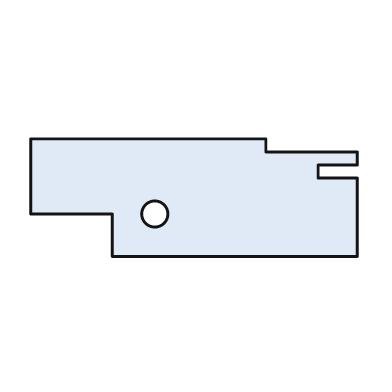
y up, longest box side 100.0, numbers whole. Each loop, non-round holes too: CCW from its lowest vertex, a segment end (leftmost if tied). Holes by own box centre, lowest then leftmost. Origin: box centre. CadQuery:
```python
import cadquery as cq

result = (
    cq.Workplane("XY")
    .moveTo(-25.0, -18.0)
    .lineTo(50.0, -18.0)
    .lineTo(50.0, 6.0)
    .lineTo(38.0, 6.0)
    .lineTo(38.0, 10.0)
    .lineTo(50.0, 10.0)
    .lineTo(50.0, 14.0)
    .lineTo(22.0, 14.0)
    .lineTo(22.0, 18.0)
    .lineTo(-50.0, 18.0)
    .lineTo(-50.0, -5.0)
    .lineTo(-25.0, -5.0)
    .close()
    .moveTo(-12.0, -5.0)
    .circle(4.0)
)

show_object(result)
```